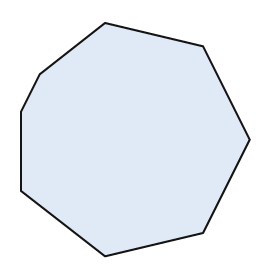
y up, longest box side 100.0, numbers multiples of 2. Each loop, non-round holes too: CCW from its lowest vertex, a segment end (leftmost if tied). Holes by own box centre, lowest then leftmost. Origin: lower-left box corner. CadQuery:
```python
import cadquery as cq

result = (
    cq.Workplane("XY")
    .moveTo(36.0, 0.0)
    .lineTo(78.0, 10.0)
    .lineTo(98.0, 50.0)
    .lineTo(78.0, 90.0)
    .lineTo(36.0, 100.0)
    .lineTo(8.0, 78.0)
    .lineTo(0.0, 62.0)
    .lineTo(0.0, 28.0)
    .close()
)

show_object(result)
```